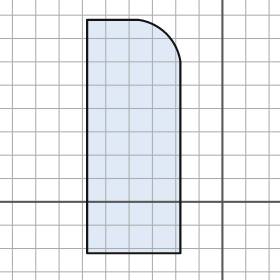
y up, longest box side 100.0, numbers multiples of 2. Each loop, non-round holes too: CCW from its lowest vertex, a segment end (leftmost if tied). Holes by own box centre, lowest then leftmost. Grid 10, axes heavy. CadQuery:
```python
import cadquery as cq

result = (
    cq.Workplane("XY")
    .moveTo(-58.0, -22.0)
    .lineTo(-18.0, -22.0)
    .lineTo(-18.0, 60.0)
    .threePointArc((-24.0, 72.0), (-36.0, 78.0))
    .lineTo(-58.0, 78.0)
    .close()
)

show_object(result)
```